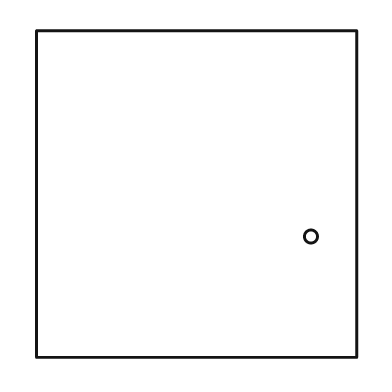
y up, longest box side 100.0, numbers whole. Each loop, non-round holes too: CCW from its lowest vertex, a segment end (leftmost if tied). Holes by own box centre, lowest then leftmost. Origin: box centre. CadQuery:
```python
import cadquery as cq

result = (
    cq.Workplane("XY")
    .moveTo(-49.0, -50.0)
    .lineTo(49.0, -50.0)
    .lineTo(49.0, 50.0)
    .lineTo(-49.0, 50.0)
    .close()
    .moveTo(35.0, -13.0)
    .circle(2.0)
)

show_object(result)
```